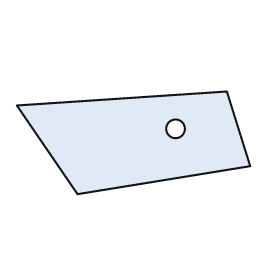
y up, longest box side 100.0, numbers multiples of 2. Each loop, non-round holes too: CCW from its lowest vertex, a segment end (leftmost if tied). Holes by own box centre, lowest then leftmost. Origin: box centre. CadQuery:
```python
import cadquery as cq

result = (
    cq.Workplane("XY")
    .moveTo(-24.0, -22.0)
    .lineTo(50.0, -10.0)
    .lineTo(40.0, 22.0)
    .lineTo(-50.0, 16.0)
    .close()
    .moveTo(18.0, 6.0)
    .circle(4.0)
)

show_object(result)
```